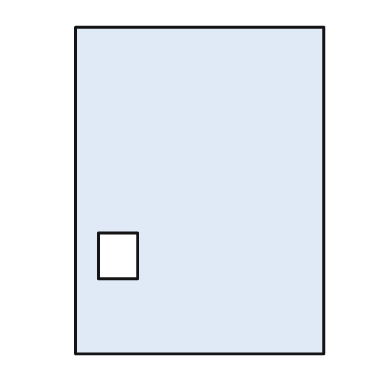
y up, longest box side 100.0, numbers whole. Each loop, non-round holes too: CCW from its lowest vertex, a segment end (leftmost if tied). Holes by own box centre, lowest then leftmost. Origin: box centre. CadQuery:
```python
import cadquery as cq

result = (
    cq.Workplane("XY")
    .moveTo(-38.0, -50.0)
    .lineTo(38.0, -50.0)
    .lineTo(38.0, 50.0)
    .lineTo(-38.0, 50.0)
    .close()
    .moveTo(-31.0, -27.0)
    .lineTo(-19.0, -27.0)
    .lineTo(-19.0, -13.0)
    .lineTo(-31.0, -13.0)
    .close()
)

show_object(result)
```